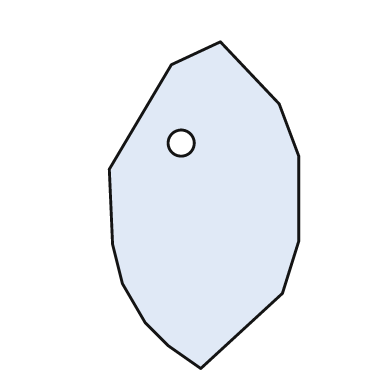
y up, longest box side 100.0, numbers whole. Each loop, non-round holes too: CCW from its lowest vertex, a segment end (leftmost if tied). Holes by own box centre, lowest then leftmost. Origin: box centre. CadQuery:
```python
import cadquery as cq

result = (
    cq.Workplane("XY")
    .moveTo(-1.0, -50.0)
    .lineTo(24.0, -27.0)
    .lineTo(29.0, -11.0)
    .lineTo(29.0, 15.0)
    .lineTo(23.0, 31.0)
    .lineTo(5.0, 50.0)
    .lineTo(-10.0, 43.0)
    .lineTo(-29.0, 11.0)
    .lineTo(-28.0, -12.0)
    .lineTo(-25.0, -24.0)
    .lineTo(-18.0, -36.0)
    .lineTo(-11.0, -43.0)
    .close()
    .moveTo(-7.0, 19.0)
    .circle(4.0)
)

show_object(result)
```